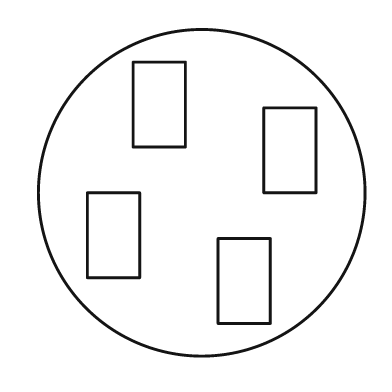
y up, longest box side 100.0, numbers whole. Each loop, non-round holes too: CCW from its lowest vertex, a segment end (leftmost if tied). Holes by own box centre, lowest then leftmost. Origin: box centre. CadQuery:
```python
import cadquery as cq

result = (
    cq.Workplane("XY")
    .moveTo(0.0, 0.0)
    .circle(50.0)
    .moveTo(5.0, -40.0)
    .lineTo(21.0, -40.0)
    .lineTo(21.0, -14.0)
    .lineTo(5.0, -14.0)
    .close()
    .moveTo(-35.0, -26.0)
    .lineTo(-19.0, -26.0)
    .lineTo(-19.0, 0.0)
    .lineTo(-35.0, 0.0)
    .close()
    .moveTo(19.0, 0.0)
    .lineTo(35.0, 0.0)
    .lineTo(35.0, 26.0)
    .lineTo(19.0, 26.0)
    .close()
    .moveTo(-21.0, 14.0)
    .lineTo(-5.0, 14.0)
    .lineTo(-5.0, 40.0)
    .lineTo(-21.0, 40.0)
    .close()
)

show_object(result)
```